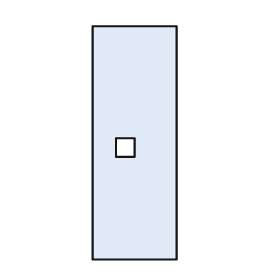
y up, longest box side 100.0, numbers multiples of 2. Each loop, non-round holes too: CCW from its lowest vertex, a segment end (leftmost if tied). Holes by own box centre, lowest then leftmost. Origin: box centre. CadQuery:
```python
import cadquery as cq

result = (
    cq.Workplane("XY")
    .moveTo(-18.0, -50.0)
    .lineTo(18.0, -50.0)
    .lineTo(18.0, 50.0)
    .lineTo(-18.0, 50.0)
    .close()
    .moveTo(-8.0, -6.0)
    .lineTo(0.0, -6.0)
    .lineTo(0.0, 2.0)
    .lineTo(-8.0, 2.0)
    .close()
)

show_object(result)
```